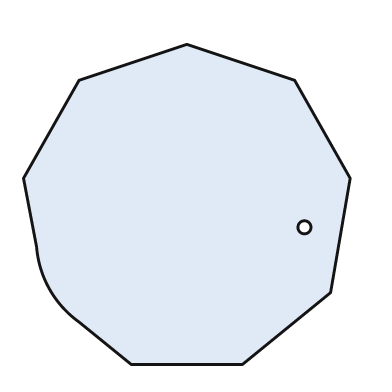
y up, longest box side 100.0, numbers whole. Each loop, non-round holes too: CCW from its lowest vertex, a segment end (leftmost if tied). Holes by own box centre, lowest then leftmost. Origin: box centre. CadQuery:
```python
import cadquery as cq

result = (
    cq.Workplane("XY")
    .moveTo(-17.0, -49.0)
    .lineTo(17.0, -49.0)
    .lineTo(44.0, -27.0)
    .lineTo(50.0, 8.0)
    .lineTo(33.0, 38.0)
    .lineTo(0.0, 49.0)
    .lineTo(-33.0, 38.0)
    .lineTo(-50.0, 8.0)
    .lineTo(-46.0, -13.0)
    .threePointArc((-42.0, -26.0), (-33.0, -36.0))
    .close()
    .moveTo(36.0, -7.0)
    .circle(2.0)
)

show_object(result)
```